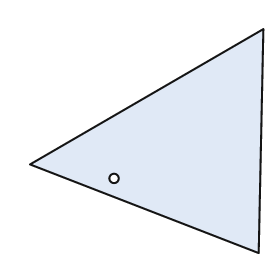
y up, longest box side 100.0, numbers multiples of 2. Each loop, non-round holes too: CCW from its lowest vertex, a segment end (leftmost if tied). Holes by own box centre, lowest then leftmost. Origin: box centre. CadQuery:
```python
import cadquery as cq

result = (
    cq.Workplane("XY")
    .moveTo(48.0, -48.0)
    .lineTo(50.0, 48.0)
    .lineTo(-50.0, -10.0)
    .close()
    .moveTo(-14.0, -16.0)
    .circle(2.0)
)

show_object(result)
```